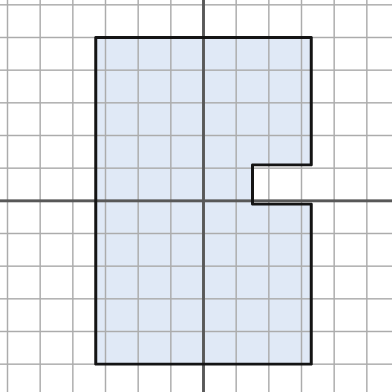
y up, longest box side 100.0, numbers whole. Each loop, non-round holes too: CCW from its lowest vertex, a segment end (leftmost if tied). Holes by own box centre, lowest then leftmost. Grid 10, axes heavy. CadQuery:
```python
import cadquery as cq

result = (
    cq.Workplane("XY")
    .moveTo(-33.0, -50.0)
    .lineTo(33.0, -50.0)
    .lineTo(33.0, -1.0)
    .lineTo(15.0, -1.0)
    .lineTo(15.0, 11.0)
    .lineTo(33.0, 11.0)
    .lineTo(33.0, 50.0)
    .lineTo(-33.0, 50.0)
    .close()
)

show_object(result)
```